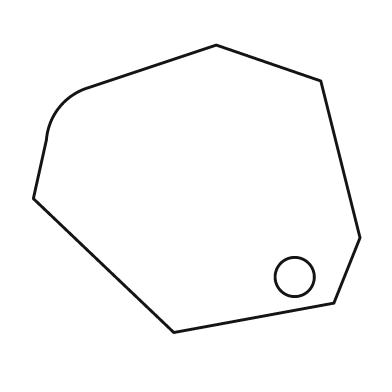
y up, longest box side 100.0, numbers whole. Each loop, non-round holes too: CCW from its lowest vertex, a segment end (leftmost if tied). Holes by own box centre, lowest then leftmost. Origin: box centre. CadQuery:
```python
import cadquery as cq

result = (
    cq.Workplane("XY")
    .moveTo(-7.0, -44.0)
    .lineTo(42.0, -35.0)
    .lineTo(50.0, -15.0)
    .lineTo(38.0, 33.0)
    .lineTo(6.0, 44.0)
    .lineTo(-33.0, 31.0)
    .threePointArc((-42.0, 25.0), (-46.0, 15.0))
    .lineTo(-50.0, -3.0)
    .close()
    .moveTo(30.0, -27.0)
    .circle(6.0)
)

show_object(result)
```